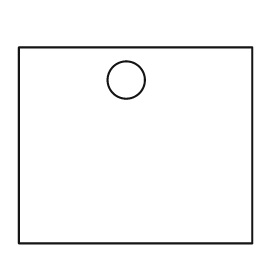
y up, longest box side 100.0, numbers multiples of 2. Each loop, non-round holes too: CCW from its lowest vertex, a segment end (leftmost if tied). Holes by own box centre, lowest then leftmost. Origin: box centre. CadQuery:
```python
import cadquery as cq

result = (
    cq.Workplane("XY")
    .moveTo(-50.0, -42.0)
    .lineTo(50.0, -42.0)
    .lineTo(50.0, 42.0)
    .lineTo(-50.0, 42.0)
    .close()
    .moveTo(-4.0, 28.0)
    .circle(8.0)
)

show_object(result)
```